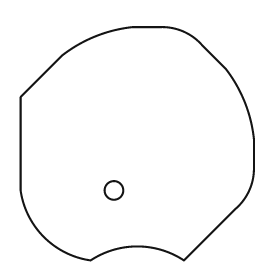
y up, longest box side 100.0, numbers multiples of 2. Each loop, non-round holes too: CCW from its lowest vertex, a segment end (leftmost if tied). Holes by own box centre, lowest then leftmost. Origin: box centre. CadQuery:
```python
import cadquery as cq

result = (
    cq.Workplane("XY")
    .moveTo(-20.0, -50.0)
    .threePointArc((0.0, -44.0), (20.0, -50.0))
    .lineTo(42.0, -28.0)
    .threePointArc((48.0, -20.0), (50.0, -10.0))
    .lineTo(50.0, 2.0)
    .threePointArc((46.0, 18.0), (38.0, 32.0))
    .lineTo(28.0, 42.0)
    .threePointArc((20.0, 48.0), (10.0, 50.0))
    .lineTo(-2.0, 50.0)
    .threePointArc((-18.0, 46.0), (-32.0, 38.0))
    .lineTo(-50.0, 20.0)
    .lineTo(-50.0, -20.0)
    .threePointArc((-40.0, -40.0), (-20.0, -50.0))
    .close()
    .moveTo(-10.0, -20.0)
    .circle(4.0)
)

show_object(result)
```